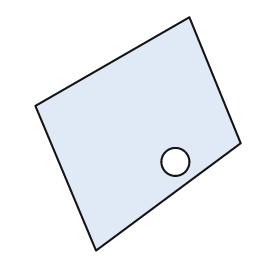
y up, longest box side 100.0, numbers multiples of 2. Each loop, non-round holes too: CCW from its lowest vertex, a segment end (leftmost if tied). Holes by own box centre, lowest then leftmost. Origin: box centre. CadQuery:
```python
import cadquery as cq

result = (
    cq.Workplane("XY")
    .moveTo(-18.0, -50.0)
    .lineTo(44.0, -4.0)
    .lineTo(22.0, 50.0)
    .lineTo(-44.0, 12.0)
    .close()
    .moveTo(16.0, -12.0)
    .circle(6.0)
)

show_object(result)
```